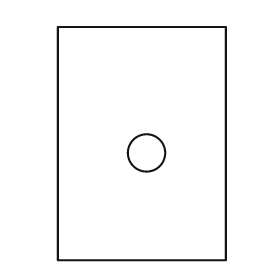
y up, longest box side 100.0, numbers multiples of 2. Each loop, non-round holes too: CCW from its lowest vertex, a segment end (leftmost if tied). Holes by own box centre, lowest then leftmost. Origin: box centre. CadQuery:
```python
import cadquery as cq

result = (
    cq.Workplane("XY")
    .moveTo(-36.0, -50.0)
    .lineTo(36.0, -50.0)
    .lineTo(36.0, 50.0)
    .lineTo(-36.0, 50.0)
    .close()
    .moveTo(2.0, -4.0)
    .circle(8.0)
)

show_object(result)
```